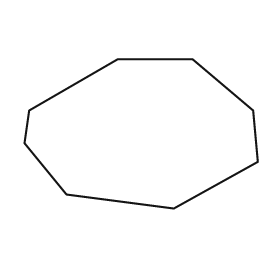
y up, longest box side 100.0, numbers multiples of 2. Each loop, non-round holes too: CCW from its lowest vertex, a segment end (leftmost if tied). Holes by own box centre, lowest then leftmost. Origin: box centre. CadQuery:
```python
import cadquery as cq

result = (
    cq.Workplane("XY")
    .moveTo(14.0, -32.0)
    .lineTo(50.0, -12.0)
    .lineTo(48.0, 10.0)
    .lineTo(22.0, 32.0)
    .lineTo(-10.0, 32.0)
    .lineTo(-48.0, 10.0)
    .lineTo(-50.0, -4.0)
    .lineTo(-32.0, -26.0)
    .close()
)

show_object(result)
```